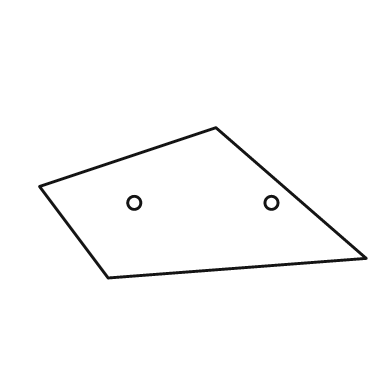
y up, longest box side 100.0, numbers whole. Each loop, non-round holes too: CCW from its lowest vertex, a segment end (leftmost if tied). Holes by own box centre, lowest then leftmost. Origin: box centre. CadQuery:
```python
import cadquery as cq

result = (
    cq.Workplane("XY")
    .moveTo(-29.0, -23.0)
    .lineTo(50.0, -17.0)
    .lineTo(4.0, 23.0)
    .lineTo(-50.0, 5.0)
    .close()
    .moveTo(-21.0, 0.0)
    .circle(2.0)
    .moveTo(21.0, 0.0)
    .circle(2.0)
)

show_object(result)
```